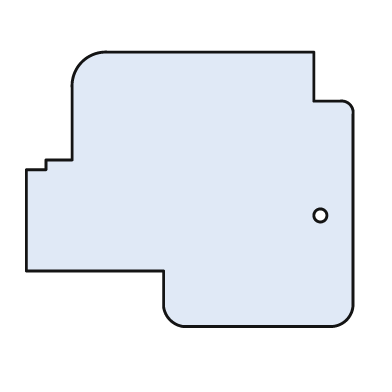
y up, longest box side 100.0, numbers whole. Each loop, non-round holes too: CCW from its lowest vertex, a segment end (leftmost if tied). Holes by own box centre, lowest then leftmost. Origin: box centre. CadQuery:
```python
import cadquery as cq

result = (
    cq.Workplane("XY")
    .moveTo(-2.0, -42.0)
    .lineTo(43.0, -42.0)
    .threePointArc((48.0, -40.0), (50.0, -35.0))
    .lineTo(50.0, 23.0)
    .threePointArc((49.0, 26.0), (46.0, 27.0))
    .lineTo(38.0, 27.0)
    .lineTo(38.0, 42.0)
    .lineTo(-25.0, 42.0)
    .threePointArc((-33.0, 39.0), (-36.0, 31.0))
    .lineTo(-36.0, 9.0)
    .lineTo(-44.0, 9.0)
    .lineTo(-44.0, 6.0)
    .lineTo(-50.0, 6.0)
    .lineTo(-50.0, -25.0)
    .lineTo(-8.0, -25.0)
    .lineTo(-8.0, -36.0)
    .threePointArc((-6.0, -40.0), (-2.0, -42.0))
    .close()
    .moveTo(40.0, -8.0)
    .circle(2.0)
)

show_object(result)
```